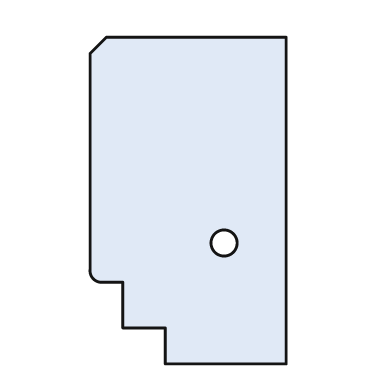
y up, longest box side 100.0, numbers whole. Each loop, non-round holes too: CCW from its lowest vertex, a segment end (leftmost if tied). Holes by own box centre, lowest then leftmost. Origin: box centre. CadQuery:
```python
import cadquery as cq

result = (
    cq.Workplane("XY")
    .moveTo(-7.0, -50.0)
    .lineTo(30.0, -50.0)
    .lineTo(30.0, 50.0)
    .lineTo(-25.0, 50.0)
    .lineTo(-30.0, 45.0)
    .lineTo(-30.0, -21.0)
    .threePointArc((-29.0, -24.0), (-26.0, -25.0))
    .lineTo(-20.0, -25.0)
    .lineTo(-20.0, -39.0)
    .lineTo(-7.0, -39.0)
    .close()
    .moveTo(11.0, -13.0)
    .circle(4.0)
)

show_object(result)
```